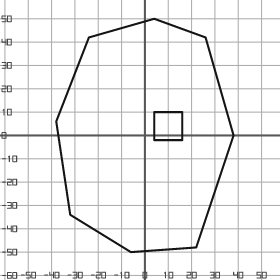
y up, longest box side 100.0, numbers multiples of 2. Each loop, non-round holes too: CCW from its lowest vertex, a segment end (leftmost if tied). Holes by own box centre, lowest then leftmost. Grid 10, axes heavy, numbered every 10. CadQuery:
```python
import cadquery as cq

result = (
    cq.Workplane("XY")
    .moveTo(-6.0, -50.0)
    .lineTo(22.0, -48.0)
    .lineTo(38.0, 0.0)
    .lineTo(26.0, 42.0)
    .lineTo(4.0, 50.0)
    .lineTo(-24.0, 42.0)
    .lineTo(-38.0, 6.0)
    .lineTo(-32.0, -34.0)
    .close()
    .moveTo(4.0, -2.0)
    .lineTo(16.0, -2.0)
    .lineTo(16.0, 10.0)
    .lineTo(4.0, 10.0)
    .close()
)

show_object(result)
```